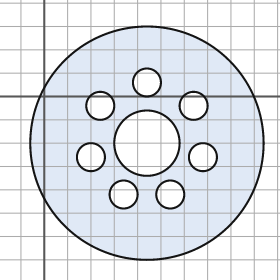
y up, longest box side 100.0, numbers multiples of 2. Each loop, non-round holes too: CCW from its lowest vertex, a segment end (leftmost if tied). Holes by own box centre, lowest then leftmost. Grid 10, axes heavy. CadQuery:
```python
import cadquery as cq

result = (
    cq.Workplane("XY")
    .moveTo(44.0, -20.0)
    .circle(50.0)
    .moveTo(34.0, -42.0)
    .circle(6.0)
    .moveTo(54.0, -42.0)
    .circle(6.0)
    .moveTo(20.0, -26.0)
    .circle(6.0)
    .moveTo(68.0, -26.0)
    .circle(6.0)
    .moveTo(44.0, -20.0)
    .circle(14.0)
    .moveTo(24.0, -4.0)
    .circle(6.0)
    .moveTo(64.0, -4.0)
    .circle(6.0)
    .moveTo(44.0, 6.0)
    .circle(6.0)
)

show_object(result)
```